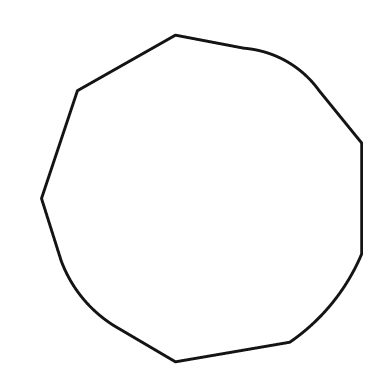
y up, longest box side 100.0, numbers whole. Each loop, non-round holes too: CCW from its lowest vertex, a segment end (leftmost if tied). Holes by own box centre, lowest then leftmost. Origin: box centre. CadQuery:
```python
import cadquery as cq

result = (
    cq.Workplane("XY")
    .moveTo(-8.0, -50.0)
    .lineTo(27.0, -44.0)
    .threePointArc((40.0, -32.0), (49.0, -17.0))
    .lineTo(49.0, 17.0)
    .lineTo(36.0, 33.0)
    .threePointArc((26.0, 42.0), (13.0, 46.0))
    .lineTo(-8.0, 50.0)
    .lineTo(-38.0, 33.0)
    .lineTo(-49.0, 0.0)
    .lineTo(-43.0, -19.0)
    .threePointArc((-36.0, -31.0), (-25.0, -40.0))
    .close()
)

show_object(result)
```